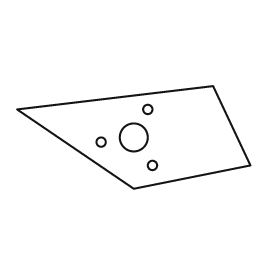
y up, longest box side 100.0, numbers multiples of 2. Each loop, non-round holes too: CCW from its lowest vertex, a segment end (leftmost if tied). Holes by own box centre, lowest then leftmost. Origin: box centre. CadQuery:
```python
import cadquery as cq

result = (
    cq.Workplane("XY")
    .moveTo(0.0, -22.0)
    .lineTo(50.0, -12.0)
    .lineTo(34.0, 22.0)
    .lineTo(-50.0, 12.0)
    .close()
    .moveTo(8.0, -12.0)
    .circle(2.0)
    .moveTo(-14.0, -2.0)
    .circle(2.0)
    .moveTo(0.0, 0.0)
    .circle(6.0)
    .moveTo(6.0, 12.0)
    .circle(2.0)
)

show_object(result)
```